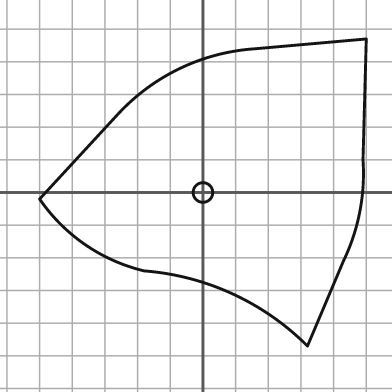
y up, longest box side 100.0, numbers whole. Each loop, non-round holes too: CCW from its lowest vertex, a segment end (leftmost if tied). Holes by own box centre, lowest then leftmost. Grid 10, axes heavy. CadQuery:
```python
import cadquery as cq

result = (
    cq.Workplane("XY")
    .moveTo(32.0, -47.0)
    .lineTo(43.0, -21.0)
    .threePointArc((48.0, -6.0), (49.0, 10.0))
    .lineTo(50.0, 47.0)
    .lineTo(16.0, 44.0)
    .threePointArc((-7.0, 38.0), (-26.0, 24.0))
    .lineTo(-50.0, -2.0)
    .threePointArc((-36.0, -16.0), (-18.0, -24.0))
    .threePointArc((9.0, -31.0), (32.0, -47.0))
    .close()
    .moveTo(0.0, 0.0)
    .circle(3.0)
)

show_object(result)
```